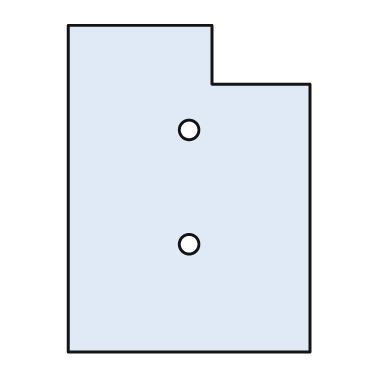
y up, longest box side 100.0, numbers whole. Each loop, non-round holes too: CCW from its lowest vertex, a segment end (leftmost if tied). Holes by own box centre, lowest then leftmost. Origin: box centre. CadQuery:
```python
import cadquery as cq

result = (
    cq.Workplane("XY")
    .moveTo(-37.0, -50.0)
    .lineTo(37.0, -50.0)
    .lineTo(37.0, 32.0)
    .lineTo(7.0, 32.0)
    .lineTo(7.0, 50.0)
    .lineTo(-37.0, 50.0)
    .close()
    .moveTo(0.0, -17.0)
    .circle(3.0)
    .moveTo(0.0, 18.0)
    .circle(3.0)
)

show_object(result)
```